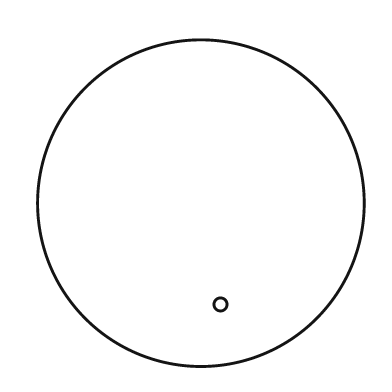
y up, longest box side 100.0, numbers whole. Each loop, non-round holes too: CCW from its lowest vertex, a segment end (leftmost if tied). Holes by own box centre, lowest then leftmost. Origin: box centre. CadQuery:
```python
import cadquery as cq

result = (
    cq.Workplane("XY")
    .moveTo(0.0, 0.0)
    .circle(50.0)
    .moveTo(6.0, -31.0)
    .circle(2.0)
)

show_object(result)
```